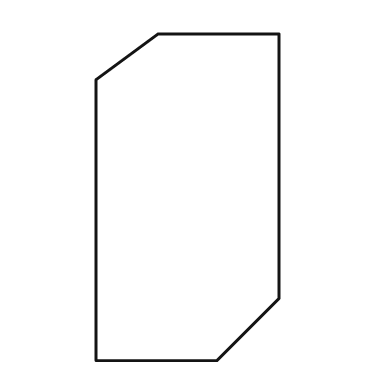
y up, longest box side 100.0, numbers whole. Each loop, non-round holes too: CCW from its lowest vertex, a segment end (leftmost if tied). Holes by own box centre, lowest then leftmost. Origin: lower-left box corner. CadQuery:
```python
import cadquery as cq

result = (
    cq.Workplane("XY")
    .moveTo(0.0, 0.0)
    .lineTo(37.0, 0.0)
    .lineTo(56.0, 19.0)
    .lineTo(56.0, 100.0)
    .lineTo(19.0, 100.0)
    .lineTo(0.0, 86.0)
    .close()
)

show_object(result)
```